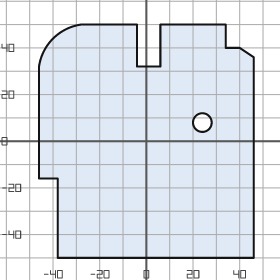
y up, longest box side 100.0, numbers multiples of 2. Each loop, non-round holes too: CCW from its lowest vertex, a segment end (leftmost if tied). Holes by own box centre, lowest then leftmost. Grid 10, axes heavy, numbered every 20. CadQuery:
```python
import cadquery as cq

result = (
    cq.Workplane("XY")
    .moveTo(-38.0, -50.0)
    .lineTo(46.0, -50.0)
    .lineTo(46.0, 36.0)
    .lineTo(40.0, 40.0)
    .lineTo(34.0, 40.0)
    .lineTo(34.0, 50.0)
    .lineTo(6.0, 50.0)
    .lineTo(6.0, 32.0)
    .lineTo(-4.0, 32.0)
    .lineTo(-4.0, 50.0)
    .lineTo(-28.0, 50.0)
    .threePointArc((-40.0, 44.0), (-46.0, 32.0))
    .lineTo(-46.0, -16.0)
    .lineTo(-38.0, -16.0)
    .close()
    .moveTo(24.0, 8.0)
    .circle(4.0)
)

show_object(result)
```